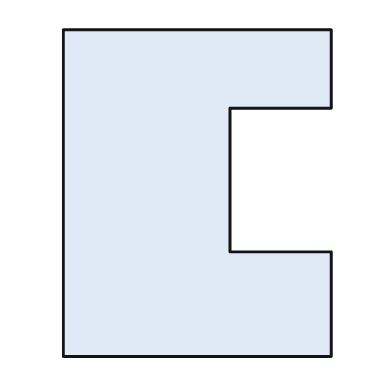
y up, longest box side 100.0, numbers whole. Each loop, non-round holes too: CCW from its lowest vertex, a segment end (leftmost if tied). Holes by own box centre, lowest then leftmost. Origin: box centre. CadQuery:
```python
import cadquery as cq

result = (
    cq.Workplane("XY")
    .moveTo(-41.0, -50.0)
    .lineTo(41.0, -50.0)
    .lineTo(41.0, -18.0)
    .lineTo(10.0, -18.0)
    .lineTo(10.0, 26.0)
    .lineTo(41.0, 26.0)
    .lineTo(41.0, 50.0)
    .lineTo(-41.0, 50.0)
    .close()
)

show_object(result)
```